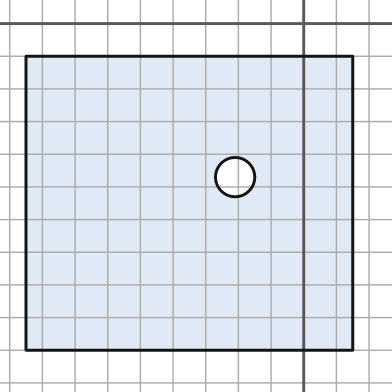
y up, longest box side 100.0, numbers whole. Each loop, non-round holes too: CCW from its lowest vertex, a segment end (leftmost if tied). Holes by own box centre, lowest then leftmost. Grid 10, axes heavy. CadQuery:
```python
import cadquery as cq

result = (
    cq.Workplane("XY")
    .moveTo(-85.0, -100.0)
    .lineTo(15.0, -100.0)
    .lineTo(15.0, -10.0)
    .lineTo(-85.0, -10.0)
    .close()
    .moveTo(-21.0, -47.0)
    .circle(6.0)
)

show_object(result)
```